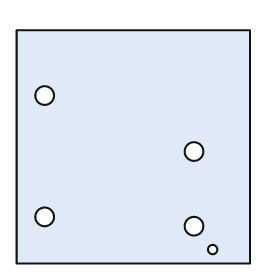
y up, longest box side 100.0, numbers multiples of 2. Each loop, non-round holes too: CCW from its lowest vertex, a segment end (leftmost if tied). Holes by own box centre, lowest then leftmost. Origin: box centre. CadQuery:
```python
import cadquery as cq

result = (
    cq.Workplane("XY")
    .moveTo(-50.0, -50.0)
    .lineTo(50.0, -50.0)
    .lineTo(50.0, 50.0)
    .lineTo(-50.0, 50.0)
    .close()
    .moveTo(34.0, -44.0)
    .circle(2.0)
    .moveTo(26.0, -34.0)
    .circle(4.0)
    .moveTo(-38.0, -30.0)
    .circle(4.0)
    .moveTo(26.0, -2.0)
    .circle(4.0)
    .moveTo(-38.0, 22.0)
    .circle(4.0)
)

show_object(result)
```